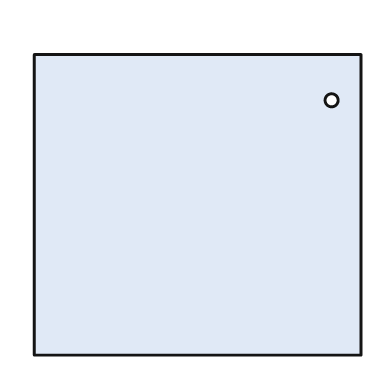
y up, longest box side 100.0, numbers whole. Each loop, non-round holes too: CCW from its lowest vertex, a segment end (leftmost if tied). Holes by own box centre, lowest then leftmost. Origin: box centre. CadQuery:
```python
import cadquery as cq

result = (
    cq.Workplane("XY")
    .moveTo(-50.0, -46.0)
    .lineTo(50.0, -46.0)
    .lineTo(50.0, 46.0)
    .lineTo(-50.0, 46.0)
    .close()
    .moveTo(41.0, 32.0)
    .circle(2.0)
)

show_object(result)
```